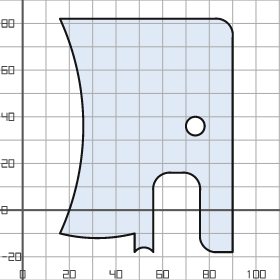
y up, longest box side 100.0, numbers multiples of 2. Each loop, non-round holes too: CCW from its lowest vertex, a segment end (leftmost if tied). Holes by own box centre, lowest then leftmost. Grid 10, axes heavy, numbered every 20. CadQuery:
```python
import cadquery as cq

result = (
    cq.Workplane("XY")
    .moveTo(48.0, -18.0)
    .threePointArc((52.0, -16.0), (56.0, -18.0))
    .lineTo(56.0, 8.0)
    .threePointArc((58.0, 14.0), (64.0, 16.0))
    .lineTo(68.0, 16.0)
    .threePointArc((74.0, 14.0), (76.0, 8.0))
    .lineTo(76.0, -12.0)
    .threePointArc((78.0, -16.0), (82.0, -18.0))
    .lineTo(90.0, -18.0)
    .lineTo(90.0, 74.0)
    .threePointArc((88.0, 80.0), (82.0, 82.0))
    .lineTo(16.0, 82.0)
    .threePointArc((26.0, 36.0), (16.0, -10.0))
    .threePointArc((32.0, -12.0), (48.0, -10.0))
    .close()
    .moveTo(74.0, 36.0)
    .circle(4.0)
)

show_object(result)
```